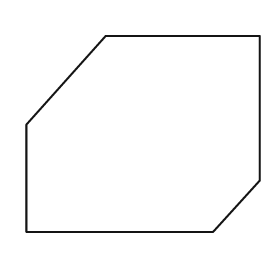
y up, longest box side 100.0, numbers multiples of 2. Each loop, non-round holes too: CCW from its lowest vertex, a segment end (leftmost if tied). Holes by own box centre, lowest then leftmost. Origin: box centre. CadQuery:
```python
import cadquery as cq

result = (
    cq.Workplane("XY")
    .moveTo(-50.0, -42.0)
    .lineTo(30.0, -42.0)
    .lineTo(50.0, -20.0)
    .lineTo(50.0, 42.0)
    .lineTo(-16.0, 42.0)
    .lineTo(-50.0, 4.0)
    .close()
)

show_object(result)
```